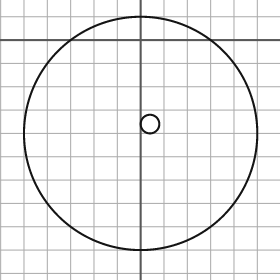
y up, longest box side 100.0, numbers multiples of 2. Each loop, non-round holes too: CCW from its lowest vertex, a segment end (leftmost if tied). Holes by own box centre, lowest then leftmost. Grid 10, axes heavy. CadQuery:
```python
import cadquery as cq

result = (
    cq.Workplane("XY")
    .moveTo(0.0, -40.0)
    .circle(50.0)
    .moveTo(4.0, -36.0)
    .circle(4.0)
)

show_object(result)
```